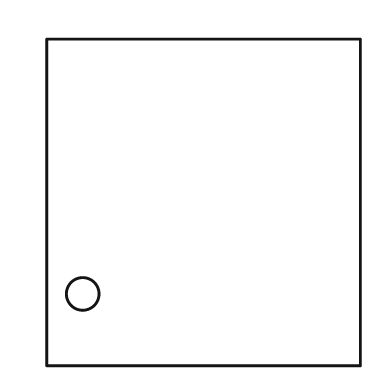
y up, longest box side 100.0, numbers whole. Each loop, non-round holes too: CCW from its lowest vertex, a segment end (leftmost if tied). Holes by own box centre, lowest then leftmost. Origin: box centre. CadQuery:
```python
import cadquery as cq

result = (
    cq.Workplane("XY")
    .moveTo(-48.0, -50.0)
    .lineTo(48.0, -50.0)
    .lineTo(48.0, 50.0)
    .lineTo(-48.0, 50.0)
    .close()
    .moveTo(-37.0, -28.0)
    .circle(5.0)
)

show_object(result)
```